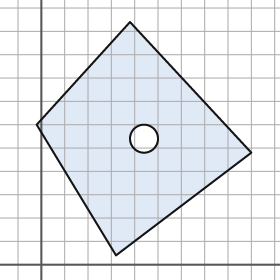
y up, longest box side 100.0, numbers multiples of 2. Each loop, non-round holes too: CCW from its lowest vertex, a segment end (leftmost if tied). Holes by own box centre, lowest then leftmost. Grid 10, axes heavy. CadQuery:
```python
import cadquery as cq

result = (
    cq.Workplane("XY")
    .moveTo(32.0, 4.0)
    .lineTo(90.0, 48.0)
    .lineTo(38.0, 104.0)
    .lineTo(-2.0, 60.0)
    .close()
    .moveTo(44.0, 54.0)
    .circle(6.0)
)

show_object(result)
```